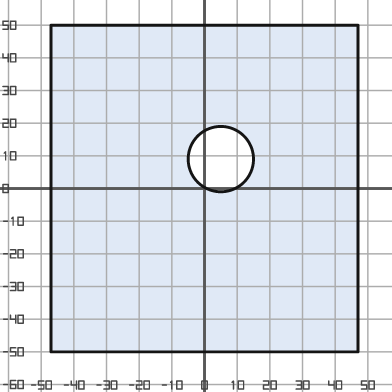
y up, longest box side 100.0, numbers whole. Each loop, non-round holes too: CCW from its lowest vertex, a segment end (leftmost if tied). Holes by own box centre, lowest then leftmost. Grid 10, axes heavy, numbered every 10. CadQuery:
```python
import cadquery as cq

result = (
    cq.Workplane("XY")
    .moveTo(-47.0, -50.0)
    .lineTo(47.0, -50.0)
    .lineTo(47.0, 50.0)
    .lineTo(-47.0, 50.0)
    .close()
    .moveTo(5.0, 9.0)
    .circle(10.0)
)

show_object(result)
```